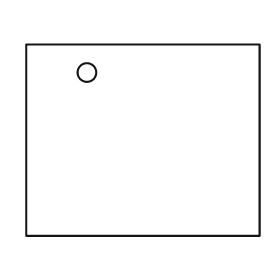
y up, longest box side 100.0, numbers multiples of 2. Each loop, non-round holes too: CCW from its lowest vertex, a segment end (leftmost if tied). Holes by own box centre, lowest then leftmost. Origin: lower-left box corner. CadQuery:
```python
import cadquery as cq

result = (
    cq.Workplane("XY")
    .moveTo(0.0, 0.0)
    .lineTo(100.0, 0.0)
    .lineTo(100.0, 82.0)
    .lineTo(0.0, 82.0)
    .close()
    .moveTo(26.0, 70.0)
    .circle(4.0)
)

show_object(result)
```